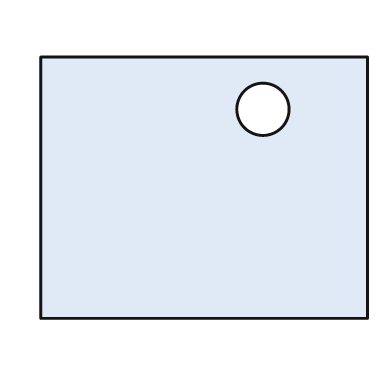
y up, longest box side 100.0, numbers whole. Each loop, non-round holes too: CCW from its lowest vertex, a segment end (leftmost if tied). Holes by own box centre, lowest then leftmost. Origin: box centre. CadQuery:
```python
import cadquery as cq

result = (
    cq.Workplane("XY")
    .moveTo(-50.0, -40.0)
    .lineTo(50.0, -40.0)
    .lineTo(50.0, 40.0)
    .lineTo(-50.0, 40.0)
    .close()
    .moveTo(18.0, 24.0)
    .circle(8.0)
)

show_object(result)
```